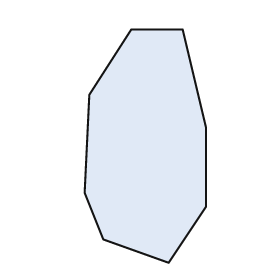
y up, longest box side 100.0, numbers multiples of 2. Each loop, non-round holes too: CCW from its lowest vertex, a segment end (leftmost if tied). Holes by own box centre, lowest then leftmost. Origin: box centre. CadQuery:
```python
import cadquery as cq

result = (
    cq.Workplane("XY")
    .moveTo(10.0, -50.0)
    .lineTo(26.0, -26.0)
    .lineTo(26.0, 8.0)
    .lineTo(16.0, 50.0)
    .lineTo(-6.0, 50.0)
    .lineTo(-24.0, 22.0)
    .lineTo(-26.0, -20.0)
    .lineTo(-18.0, -40.0)
    .close()
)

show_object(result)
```